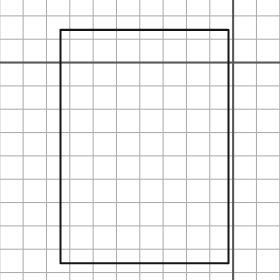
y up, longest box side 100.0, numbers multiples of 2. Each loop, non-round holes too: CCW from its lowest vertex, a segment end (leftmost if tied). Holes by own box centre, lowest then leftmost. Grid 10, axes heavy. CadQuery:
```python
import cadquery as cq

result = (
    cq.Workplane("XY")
    .moveTo(-74.0, -86.0)
    .lineTo(-2.0, -86.0)
    .lineTo(-2.0, 14.0)
    .lineTo(-74.0, 14.0)
    .close()
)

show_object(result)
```